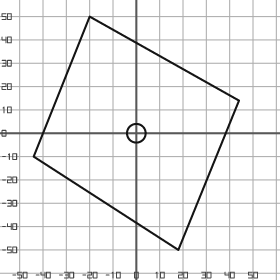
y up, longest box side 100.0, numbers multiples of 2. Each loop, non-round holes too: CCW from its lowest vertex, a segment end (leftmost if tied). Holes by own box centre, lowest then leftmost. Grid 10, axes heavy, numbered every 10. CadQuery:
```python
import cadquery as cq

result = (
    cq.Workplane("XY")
    .moveTo(18.0, -50.0)
    .lineTo(44.0, 14.0)
    .lineTo(-20.0, 50.0)
    .lineTo(-44.0, -10.0)
    .close()
    .moveTo(0.0, 0.0)
    .circle(4.0)
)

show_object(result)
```